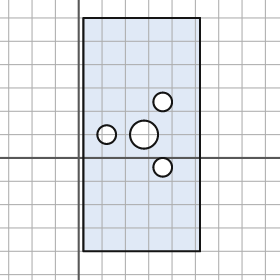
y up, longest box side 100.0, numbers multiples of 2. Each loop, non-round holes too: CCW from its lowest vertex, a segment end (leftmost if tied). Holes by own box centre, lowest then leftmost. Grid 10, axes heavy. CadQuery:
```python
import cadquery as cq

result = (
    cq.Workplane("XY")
    .moveTo(2.0, -40.0)
    .lineTo(52.0, -40.0)
    .lineTo(52.0, 60.0)
    .lineTo(2.0, 60.0)
    .close()
    .moveTo(36.0, -4.0)
    .circle(4.0)
    .moveTo(12.0, 10.0)
    .circle(4.0)
    .moveTo(28.0, 10.0)
    .circle(6.0)
    .moveTo(36.0, 24.0)
    .circle(4.0)
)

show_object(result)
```